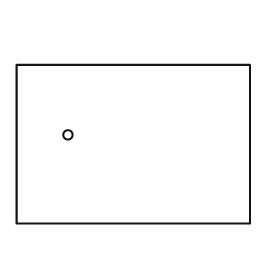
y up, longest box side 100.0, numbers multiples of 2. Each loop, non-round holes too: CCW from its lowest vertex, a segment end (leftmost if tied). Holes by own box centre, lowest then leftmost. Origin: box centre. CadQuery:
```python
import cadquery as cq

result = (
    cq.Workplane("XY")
    .moveTo(-50.0, -34.0)
    .lineTo(50.0, -34.0)
    .lineTo(50.0, 34.0)
    .lineTo(-50.0, 34.0)
    .close()
    .moveTo(-28.0, 4.0)
    .circle(2.0)
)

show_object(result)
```